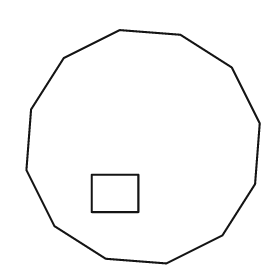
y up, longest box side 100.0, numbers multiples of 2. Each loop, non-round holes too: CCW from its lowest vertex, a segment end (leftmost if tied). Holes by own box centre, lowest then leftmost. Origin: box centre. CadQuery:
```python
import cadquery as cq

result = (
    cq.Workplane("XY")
    .moveTo(10.0, -50.0)
    .lineTo(34.0, -38.0)
    .lineTo(48.0, -16.0)
    .lineTo(50.0, 10.0)
    .lineTo(38.0, 34.0)
    .lineTo(16.0, 48.0)
    .lineTo(-10.0, 50.0)
    .lineTo(-34.0, 38.0)
    .lineTo(-48.0, 16.0)
    .lineTo(-50.0, -10.0)
    .lineTo(-38.0, -34.0)
    .lineTo(-16.0, -48.0)
    .close()
    .moveTo(-22.0, -28.0)
    .lineTo(-2.0, -28.0)
    .lineTo(-2.0, -12.0)
    .lineTo(-22.0, -12.0)
    .close()
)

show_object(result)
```